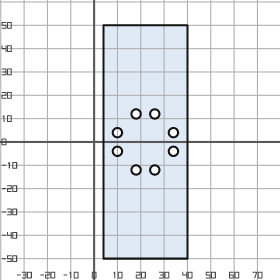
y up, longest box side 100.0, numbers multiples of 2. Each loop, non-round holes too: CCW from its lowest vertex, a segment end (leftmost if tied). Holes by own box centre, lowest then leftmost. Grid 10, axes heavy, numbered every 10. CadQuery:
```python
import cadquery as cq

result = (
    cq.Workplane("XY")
    .moveTo(4.0, -50.0)
    .lineTo(40.0, -50.0)
    .lineTo(40.0, 50.0)
    .lineTo(4.0, 50.0)
    .close()
    .moveTo(18.0, -12.0)
    .circle(2.0)
    .moveTo(26.0, -12.0)
    .circle(2.0)
    .moveTo(10.0, -4.0)
    .circle(2.0)
    .moveTo(34.0, -4.0)
    .circle(2.0)
    .moveTo(10.0, 4.0)
    .circle(2.0)
    .moveTo(34.0, 4.0)
    .circle(2.0)
    .moveTo(18.0, 12.0)
    .circle(2.0)
    .moveTo(26.0, 12.0)
    .circle(2.0)
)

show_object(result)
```